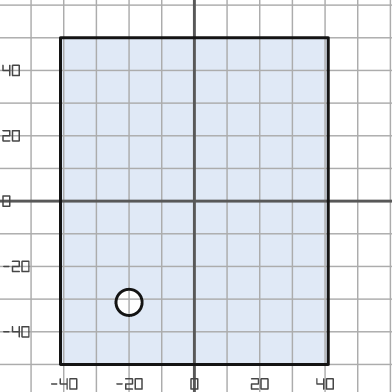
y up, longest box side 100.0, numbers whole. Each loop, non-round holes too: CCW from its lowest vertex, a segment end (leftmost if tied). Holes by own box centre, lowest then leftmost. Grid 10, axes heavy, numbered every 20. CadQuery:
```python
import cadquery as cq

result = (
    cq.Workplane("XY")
    .moveTo(-41.0, -50.0)
    .lineTo(41.0, -50.0)
    .lineTo(41.0, 50.0)
    .lineTo(-41.0, 50.0)
    .close()
    .moveTo(-20.0, -31.0)
    .circle(4.0)
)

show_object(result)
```